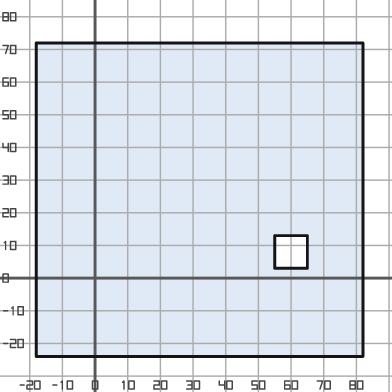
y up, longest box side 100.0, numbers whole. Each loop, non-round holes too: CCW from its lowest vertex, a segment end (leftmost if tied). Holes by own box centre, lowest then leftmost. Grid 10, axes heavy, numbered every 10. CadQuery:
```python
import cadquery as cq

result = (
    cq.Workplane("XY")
    .moveTo(-18.0, -24.0)
    .lineTo(82.0, -24.0)
    .lineTo(82.0, 72.0)
    .lineTo(-18.0, 72.0)
    .close()
    .moveTo(55.0, 3.0)
    .lineTo(65.0, 3.0)
    .lineTo(65.0, 13.0)
    .lineTo(55.0, 13.0)
    .close()
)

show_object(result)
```